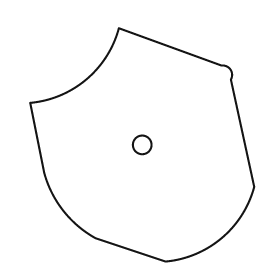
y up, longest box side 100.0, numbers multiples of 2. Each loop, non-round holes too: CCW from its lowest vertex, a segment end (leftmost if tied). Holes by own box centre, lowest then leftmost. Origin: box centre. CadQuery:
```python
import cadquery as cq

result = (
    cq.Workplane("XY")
    .moveTo(10.0, -50.0)
    .threePointArc((34.0, -40.0), (48.0, -18.0))
    .lineTo(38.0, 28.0)
    .threePointArc((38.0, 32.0), (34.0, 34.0))
    .lineTo(-10.0, 50.0)
    .threePointArc((-24.0, 28.0), (-48.0, 18.0))
    .lineTo(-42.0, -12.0)
    .threePointArc((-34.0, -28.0), (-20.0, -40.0))
    .close()
    .moveTo(0.0, 0.0)
    .circle(4.0)
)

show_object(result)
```